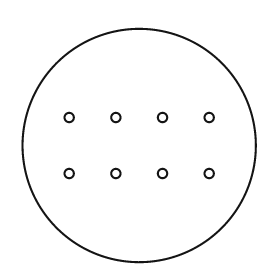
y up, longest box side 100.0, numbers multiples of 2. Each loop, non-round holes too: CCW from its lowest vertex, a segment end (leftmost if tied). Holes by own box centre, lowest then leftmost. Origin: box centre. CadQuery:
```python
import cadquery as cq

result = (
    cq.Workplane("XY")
    .moveTo(0.0, 0.0)
    .circle(50.0)
    .moveTo(-30.0, -12.0)
    .circle(2.0)
    .moveTo(-10.0, -12.0)
    .circle(2.0)
    .moveTo(10.0, -12.0)
    .circle(2.0)
    .moveTo(30.0, -12.0)
    .circle(2.0)
    .moveTo(-30.0, 12.0)
    .circle(2.0)
    .moveTo(-10.0, 12.0)
    .circle(2.0)
    .moveTo(10.0, 12.0)
    .circle(2.0)
    .moveTo(30.0, 12.0)
    .circle(2.0)
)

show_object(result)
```